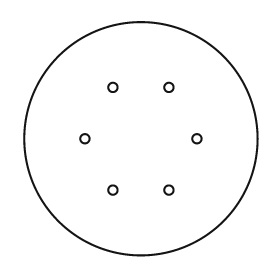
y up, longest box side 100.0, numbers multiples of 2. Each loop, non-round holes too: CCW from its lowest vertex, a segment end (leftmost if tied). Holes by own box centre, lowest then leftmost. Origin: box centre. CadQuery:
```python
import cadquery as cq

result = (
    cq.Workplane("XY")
    .moveTo(0.0, 0.0)
    .circle(50.0)
    .moveTo(-12.0, -22.0)
    .circle(2.0)
    .moveTo(12.0, -22.0)
    .circle(2.0)
    .moveTo(-24.0, 0.0)
    .circle(2.0)
    .moveTo(24.0, 0.0)
    .circle(2.0)
    .moveTo(-12.0, 22.0)
    .circle(2.0)
    .moveTo(12.0, 22.0)
    .circle(2.0)
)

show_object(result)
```